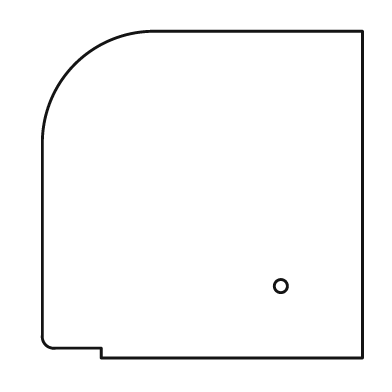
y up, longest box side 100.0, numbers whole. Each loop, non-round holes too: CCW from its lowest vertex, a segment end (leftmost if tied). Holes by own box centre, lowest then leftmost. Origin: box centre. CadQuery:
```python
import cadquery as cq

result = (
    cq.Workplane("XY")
    .moveTo(-31.0, -50.0)
    .lineTo(49.0, -50.0)
    .lineTo(49.0, 50.0)
    .lineTo(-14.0, 50.0)
    .threePointArc((-39.0, 40.0), (-49.0, 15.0))
    .lineTo(-49.0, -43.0)
    .threePointArc((-48.0, -46.0), (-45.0, -47.0))
    .lineTo(-31.0, -47.0)
    .close()
    .moveTo(24.0, -28.0)
    .circle(2.0)
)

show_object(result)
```